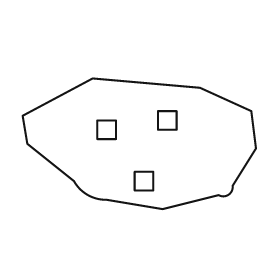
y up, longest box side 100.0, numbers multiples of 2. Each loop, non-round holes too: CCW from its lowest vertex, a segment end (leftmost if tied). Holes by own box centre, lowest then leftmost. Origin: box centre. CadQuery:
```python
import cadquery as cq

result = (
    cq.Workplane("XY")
    .moveTo(10.0, -28.0)
    .lineTo(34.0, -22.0)
    .threePointArc((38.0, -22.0), (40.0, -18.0))
    .lineTo(50.0, -2.0)
    .lineTo(48.0, 14.0)
    .lineTo(26.0, 24.0)
    .lineTo(-20.0, 28.0)
    .lineTo(-50.0, 12.0)
    .lineTo(-48.0, 0.0)
    .lineTo(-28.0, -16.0)
    .threePointArc((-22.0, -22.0), (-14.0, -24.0))
    .close()
    .moveTo(-2.0, -20.0)
    .lineTo(6.0, -20.0)
    .lineTo(6.0, -12.0)
    .lineTo(-2.0, -12.0)
    .close()
    .moveTo(-18.0, 2.0)
    .lineTo(-10.0, 2.0)
    .lineTo(-10.0, 10.0)
    .lineTo(-18.0, 10.0)
    .close()
    .moveTo(8.0, 6.0)
    .lineTo(16.0, 6.0)
    .lineTo(16.0, 14.0)
    .lineTo(8.0, 14.0)
    .close()
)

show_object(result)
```